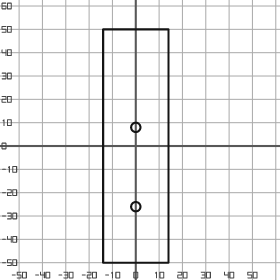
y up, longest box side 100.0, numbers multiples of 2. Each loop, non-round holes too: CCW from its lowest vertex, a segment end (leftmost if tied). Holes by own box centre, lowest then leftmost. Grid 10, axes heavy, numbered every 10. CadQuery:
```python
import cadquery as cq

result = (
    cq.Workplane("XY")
    .moveTo(-14.0, -50.0)
    .lineTo(14.0, -50.0)
    .lineTo(14.0, 50.0)
    .lineTo(-14.0, 50.0)
    .close()
    .moveTo(0.0, -26.0)
    .circle(2.0)
    .moveTo(0.0, 8.0)
    .circle(2.0)
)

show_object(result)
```